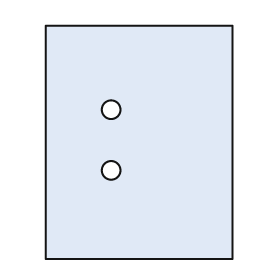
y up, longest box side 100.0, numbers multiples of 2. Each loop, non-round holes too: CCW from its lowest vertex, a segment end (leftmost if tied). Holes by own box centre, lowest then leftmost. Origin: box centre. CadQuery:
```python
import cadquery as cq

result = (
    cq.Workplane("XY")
    .moveTo(-40.0, -50.0)
    .lineTo(40.0, -50.0)
    .lineTo(40.0, 50.0)
    .lineTo(-40.0, 50.0)
    .close()
    .moveTo(-12.0, -12.0)
    .circle(4.0)
    .moveTo(-12.0, 14.0)
    .circle(4.0)
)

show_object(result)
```